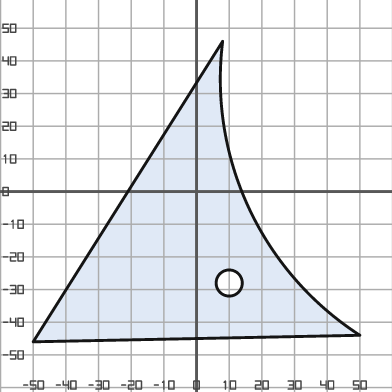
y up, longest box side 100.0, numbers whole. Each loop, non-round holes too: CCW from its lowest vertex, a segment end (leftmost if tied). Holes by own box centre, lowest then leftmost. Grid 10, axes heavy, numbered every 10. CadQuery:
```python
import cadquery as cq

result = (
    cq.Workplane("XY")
    .moveTo(-50.0, -46.0)
    .lineTo(50.0, -44.0)
    .threePointArc((16.0, -5.0), (8.0, 46.0))
    .close()
    .moveTo(10.0, -28.0)
    .circle(4.0)
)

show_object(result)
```